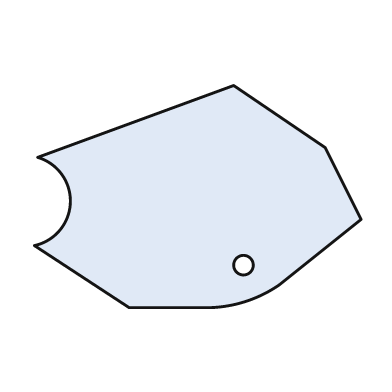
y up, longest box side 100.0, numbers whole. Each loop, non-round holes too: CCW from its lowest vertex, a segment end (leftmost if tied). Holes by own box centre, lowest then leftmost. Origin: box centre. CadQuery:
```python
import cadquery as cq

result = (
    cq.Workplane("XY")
    .moveTo(-21.0, -34.0)
    .lineTo(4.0, -34.0)
    .threePointArc((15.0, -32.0), (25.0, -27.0))
    .lineTo(50.0, -7.0)
    .lineTo(39.0, 15.0)
    .lineTo(11.0, 34.0)
    .lineTo(-49.0, 12.0)
    .threePointArc((-39.0, -2.0), (-50.0, -15.0))
    .close()
    .moveTo(14.0, -21.0)
    .circle(3.0)
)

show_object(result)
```